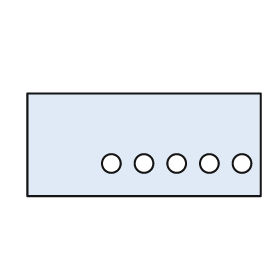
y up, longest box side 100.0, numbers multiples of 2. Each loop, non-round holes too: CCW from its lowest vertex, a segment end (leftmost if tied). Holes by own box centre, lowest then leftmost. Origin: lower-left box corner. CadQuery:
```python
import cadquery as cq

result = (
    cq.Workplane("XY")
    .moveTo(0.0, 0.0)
    .lineTo(100.0, 0.0)
    .lineTo(100.0, 44.0)
    .lineTo(0.0, 44.0)
    .close()
    .moveTo(36.0, 14.0)
    .circle(4.0)
    .moveTo(50.0, 14.0)
    .circle(4.0)
    .moveTo(64.0, 14.0)
    .circle(4.0)
    .moveTo(78.0, 14.0)
    .circle(4.0)
    .moveTo(92.0, 14.0)
    .circle(4.0)
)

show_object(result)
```